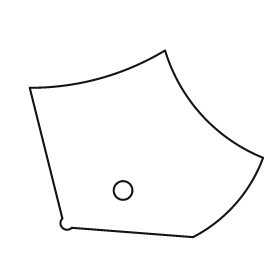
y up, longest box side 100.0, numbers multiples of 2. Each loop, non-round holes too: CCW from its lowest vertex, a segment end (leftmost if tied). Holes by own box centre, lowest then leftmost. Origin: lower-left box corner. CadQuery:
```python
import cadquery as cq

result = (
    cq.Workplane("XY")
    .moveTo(70.0, 0.0)
    .threePointArc((88.0, 14.0), (100.0, 34.0))
    .threePointArc((74.0, 52.0), (58.0, 80.0))
    .threePointArc((30.0, 68.0), (0.0, 64.0))
    .lineTo(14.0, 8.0)
    .threePointArc((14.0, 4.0), (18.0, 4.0))
    .close()
    .moveTo(40.0, 20.0)
    .circle(4.0)
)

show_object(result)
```